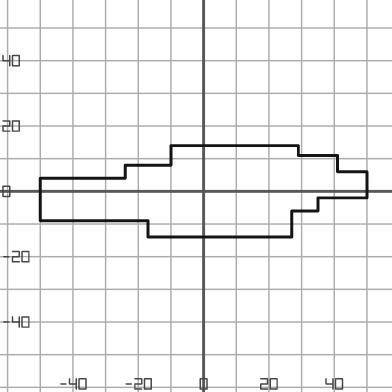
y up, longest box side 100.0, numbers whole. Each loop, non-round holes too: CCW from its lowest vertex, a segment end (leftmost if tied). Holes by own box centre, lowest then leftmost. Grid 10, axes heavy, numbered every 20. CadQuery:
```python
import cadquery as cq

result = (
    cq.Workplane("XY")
    .moveTo(-17.0, -14.0)
    .lineTo(27.0, -14.0)
    .lineTo(27.0, -6.0)
    .lineTo(35.0, -6.0)
    .lineTo(35.0, -2.0)
    .lineTo(50.0, -2.0)
    .lineTo(50.0, 6.0)
    .lineTo(41.0, 6.0)
    .lineTo(41.0, 11.0)
    .lineTo(29.0, 11.0)
    .lineTo(29.0, 14.0)
    .lineTo(-10.0, 14.0)
    .lineTo(-10.0, 8.0)
    .lineTo(-24.0, 8.0)
    .lineTo(-24.0, 4.0)
    .lineTo(-50.0, 4.0)
    .lineTo(-50.0, -9.0)
    .lineTo(-17.0, -9.0)
    .close()
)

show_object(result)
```